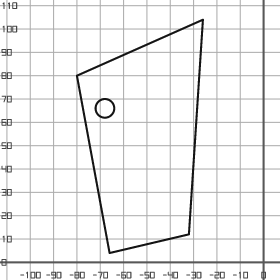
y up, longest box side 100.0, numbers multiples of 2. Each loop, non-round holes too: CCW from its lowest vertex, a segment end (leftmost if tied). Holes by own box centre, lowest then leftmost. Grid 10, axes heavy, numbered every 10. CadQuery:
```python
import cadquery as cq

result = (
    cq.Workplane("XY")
    .moveTo(-66.0, 4.0)
    .lineTo(-32.0, 12.0)
    .lineTo(-26.0, 104.0)
    .lineTo(-80.0, 80.0)
    .close()
    .moveTo(-68.0, 66.0)
    .circle(4.0)
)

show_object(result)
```